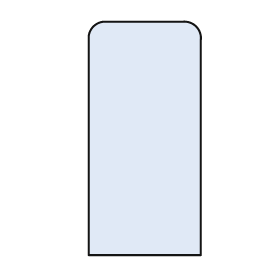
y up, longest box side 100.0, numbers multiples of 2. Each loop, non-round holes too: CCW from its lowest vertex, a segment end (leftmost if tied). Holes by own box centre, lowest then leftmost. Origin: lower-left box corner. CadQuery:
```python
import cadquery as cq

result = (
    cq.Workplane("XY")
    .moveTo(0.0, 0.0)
    .lineTo(48.0, 0.0)
    .lineTo(48.0, 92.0)
    .threePointArc((46.0, 98.0), (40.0, 100.0))
    .lineTo(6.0, 100.0)
    .threePointArc((2.0, 98.0), (0.0, 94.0))
    .close()
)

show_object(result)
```